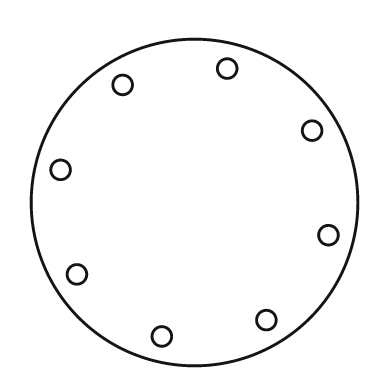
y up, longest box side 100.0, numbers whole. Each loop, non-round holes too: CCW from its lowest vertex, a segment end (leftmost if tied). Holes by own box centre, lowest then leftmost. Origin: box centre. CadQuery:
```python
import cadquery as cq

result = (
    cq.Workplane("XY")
    .moveTo(0.0, 0.0)
    .circle(50.0)
    .moveTo(-10.0, -41.0)
    .circle(3.0)
    .moveTo(22.0, -36.0)
    .circle(3.0)
    .moveTo(-36.0, -22.0)
    .circle(3.0)
    .moveTo(41.0, -10.0)
    .circle(3.0)
    .moveTo(-41.0, 10.0)
    .circle(3.0)
    .moveTo(36.0, 22.0)
    .circle(3.0)
    .moveTo(-22.0, 36.0)
    .circle(3.0)
    .moveTo(10.0, 41.0)
    .circle(3.0)
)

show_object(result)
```